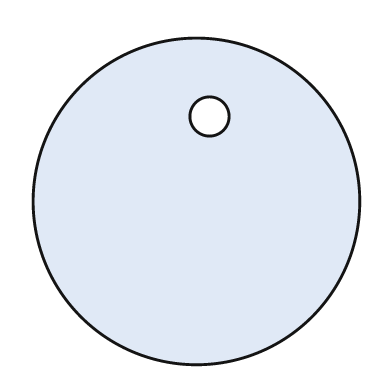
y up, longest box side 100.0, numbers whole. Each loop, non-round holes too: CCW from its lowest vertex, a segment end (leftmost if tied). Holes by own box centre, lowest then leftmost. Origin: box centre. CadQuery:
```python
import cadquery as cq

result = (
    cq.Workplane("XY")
    .moveTo(0.0, 0.0)
    .circle(50.0)
    .moveTo(4.0, 26.0)
    .circle(6.0)
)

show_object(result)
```